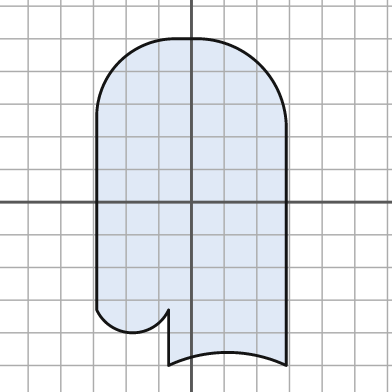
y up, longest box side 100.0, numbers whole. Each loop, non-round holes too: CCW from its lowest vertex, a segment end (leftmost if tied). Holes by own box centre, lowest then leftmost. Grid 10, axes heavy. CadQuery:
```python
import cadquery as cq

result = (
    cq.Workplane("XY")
    .moveTo(-7.0, -50.0)
    .threePointArc((11.0, -46.0), (29.0, -50.0))
    .lineTo(29.0, 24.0)
    .threePointArc((21.0, 42.0), (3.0, 50.0))
    .lineTo(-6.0, 50.0)
    .threePointArc((-22.0, 43.0), (-29.0, 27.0))
    .lineTo(-29.0, -33.0)
    .threePointArc((-18.0, -40.0), (-7.0, -33.0))
    .close()
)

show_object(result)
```